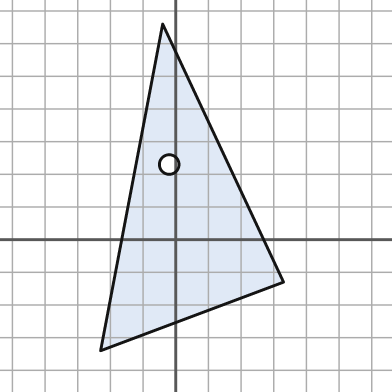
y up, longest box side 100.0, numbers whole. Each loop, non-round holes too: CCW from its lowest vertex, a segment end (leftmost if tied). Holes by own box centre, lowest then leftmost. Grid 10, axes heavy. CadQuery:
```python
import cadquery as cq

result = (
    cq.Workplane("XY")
    .moveTo(-23.0, -34.0)
    .lineTo(33.0, -13.0)
    .lineTo(-4.0, 66.0)
    .close()
    .moveTo(-2.0, 23.0)
    .circle(3.0)
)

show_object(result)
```